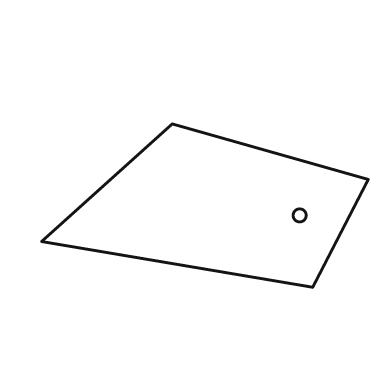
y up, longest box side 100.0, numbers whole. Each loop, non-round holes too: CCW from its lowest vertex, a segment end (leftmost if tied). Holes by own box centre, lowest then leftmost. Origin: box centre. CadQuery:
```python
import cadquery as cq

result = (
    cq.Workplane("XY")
    .moveTo(33.0, -25.0)
    .lineTo(50.0, 8.0)
    .lineTo(-10.0, 25.0)
    .lineTo(-50.0, -11.0)
    .close()
    .moveTo(29.0, -3.0)
    .circle(2.0)
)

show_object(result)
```